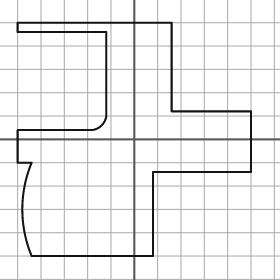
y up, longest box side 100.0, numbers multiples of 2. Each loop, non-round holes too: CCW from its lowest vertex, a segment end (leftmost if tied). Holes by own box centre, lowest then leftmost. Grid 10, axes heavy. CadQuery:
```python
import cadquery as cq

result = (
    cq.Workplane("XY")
    .moveTo(-44.0, -50.0)
    .lineTo(8.0, -50.0)
    .lineTo(8.0, -14.0)
    .lineTo(50.0, -14.0)
    .lineTo(50.0, 12.0)
    .lineTo(16.0, 12.0)
    .lineTo(16.0, 50.0)
    .lineTo(-50.0, 50.0)
    .lineTo(-50.0, 46.0)
    .lineTo(-12.0, 46.0)
    .lineTo(-12.0, 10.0)
    .threePointArc((-14.0, 6.0), (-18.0, 4.0))
    .lineTo(-50.0, 4.0)
    .lineTo(-50.0, -10.0)
    .lineTo(-44.0, -10.0)
    .threePointArc((-48.0, -30.0), (-44.0, -50.0))
    .close()
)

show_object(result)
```